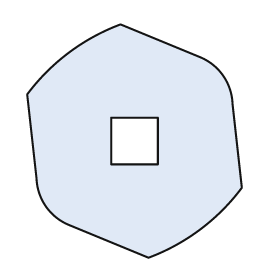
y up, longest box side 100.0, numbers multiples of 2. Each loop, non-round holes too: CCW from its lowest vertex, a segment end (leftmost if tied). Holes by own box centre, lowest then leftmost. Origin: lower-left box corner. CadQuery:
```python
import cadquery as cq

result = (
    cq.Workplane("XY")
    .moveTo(52.0, 0.0)
    .threePointArc((74.0, 12.0), (92.0, 30.0))
    .lineTo(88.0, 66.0)
    .threePointArc((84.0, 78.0), (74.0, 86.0))
    .lineTo(40.0, 100.0)
    .threePointArc((18.0, 88.0), (0.0, 70.0))
    .lineTo(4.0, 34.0)
    .threePointArc((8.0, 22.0), (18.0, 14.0))
    .close()
    .moveTo(36.0, 40.0)
    .lineTo(56.0, 40.0)
    .lineTo(56.0, 60.0)
    .lineTo(36.0, 60.0)
    .close()
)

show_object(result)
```